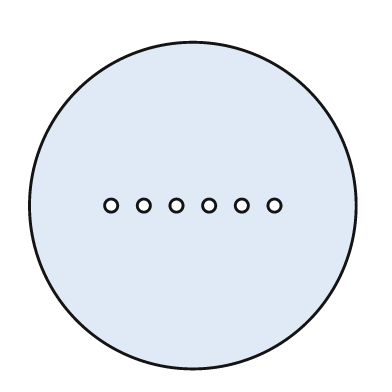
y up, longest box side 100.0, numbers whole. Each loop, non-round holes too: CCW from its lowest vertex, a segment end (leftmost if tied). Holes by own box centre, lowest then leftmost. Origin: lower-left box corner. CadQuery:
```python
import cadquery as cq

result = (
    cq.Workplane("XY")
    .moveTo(50.0, 50.0)
    .circle(50.0)
    .moveTo(25.0, 50.0)
    .circle(2.0)
    .moveTo(35.0, 50.0)
    .circle(2.0)
    .moveTo(45.0, 50.0)
    .circle(2.0)
    .moveTo(55.0, 50.0)
    .circle(2.0)
    .moveTo(65.0, 50.0)
    .circle(2.0)
    .moveTo(75.0, 50.0)
    .circle(2.0)
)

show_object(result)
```